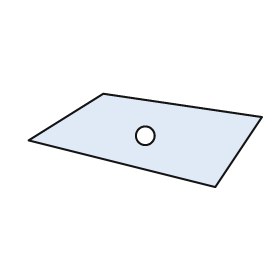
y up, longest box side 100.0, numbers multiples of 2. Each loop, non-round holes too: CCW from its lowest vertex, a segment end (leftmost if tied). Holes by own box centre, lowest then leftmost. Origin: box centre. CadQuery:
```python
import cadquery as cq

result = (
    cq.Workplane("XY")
    .moveTo(30.0, -20.0)
    .lineTo(50.0, 10.0)
    .lineTo(-18.0, 20.0)
    .lineTo(-50.0, 0.0)
    .close()
    .moveTo(0.0, 2.0)
    .circle(4.0)
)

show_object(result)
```